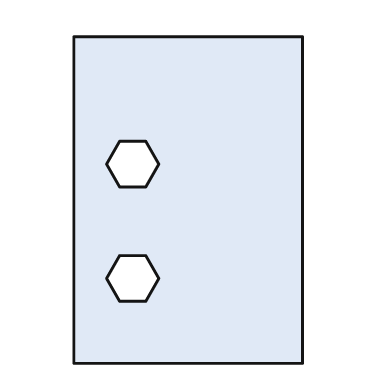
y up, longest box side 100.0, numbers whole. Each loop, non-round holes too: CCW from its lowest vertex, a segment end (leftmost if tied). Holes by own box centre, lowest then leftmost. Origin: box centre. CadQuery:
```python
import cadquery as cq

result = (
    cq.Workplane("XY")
    .moveTo(-35.0, -50.0)
    .lineTo(35.0, -50.0)
    .lineTo(35.0, 50.0)
    .lineTo(-35.0, 50.0)
    .close()
    .moveTo(-21.0, -31.0)
    .lineTo(-13.0, -31.0)
    .lineTo(-9.0, -24.0)
    .lineTo(-13.0, -17.0)
    .lineTo(-21.0, -17.0)
    .lineTo(-25.0, -24.0)
    .close()
    .moveTo(-21.0, 4.0)
    .lineTo(-13.0, 4.0)
    .lineTo(-9.0, 11.0)
    .lineTo(-13.0, 18.0)
    .lineTo(-21.0, 18.0)
    .lineTo(-25.0, 11.0)
    .close()
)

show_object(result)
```